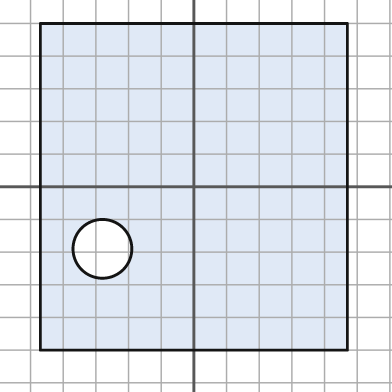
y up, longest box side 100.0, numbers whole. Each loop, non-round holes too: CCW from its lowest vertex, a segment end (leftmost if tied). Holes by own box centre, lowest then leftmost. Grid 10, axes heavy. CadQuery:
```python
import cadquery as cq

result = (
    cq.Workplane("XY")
    .moveTo(-47.0, -50.0)
    .lineTo(47.0, -50.0)
    .lineTo(47.0, 50.0)
    .lineTo(-47.0, 50.0)
    .close()
    .moveTo(-28.0, -19.0)
    .circle(9.0)
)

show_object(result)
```